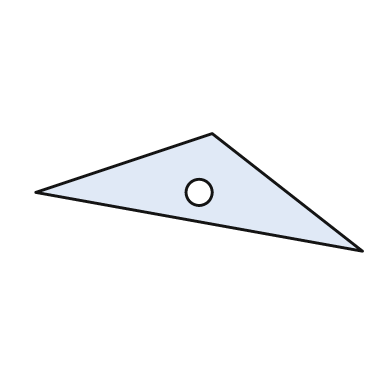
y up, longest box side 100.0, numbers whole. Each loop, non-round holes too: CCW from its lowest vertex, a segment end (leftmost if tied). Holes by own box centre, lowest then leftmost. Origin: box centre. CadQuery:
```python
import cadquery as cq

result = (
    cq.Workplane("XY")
    .moveTo(50.0, -18.0)
    .lineTo(4.0, 18.0)
    .lineTo(-50.0, 0.0)
    .close()
    .moveTo(0.0, 0.0)
    .circle(4.0)
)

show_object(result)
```